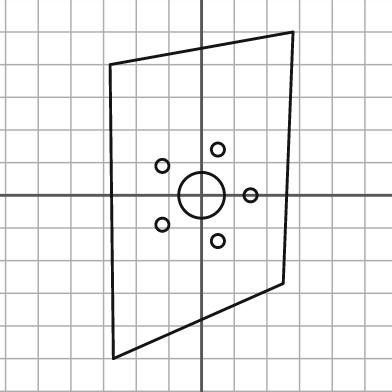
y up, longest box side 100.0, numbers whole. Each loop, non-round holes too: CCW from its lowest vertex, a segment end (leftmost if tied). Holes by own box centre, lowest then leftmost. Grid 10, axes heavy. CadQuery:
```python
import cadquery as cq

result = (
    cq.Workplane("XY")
    .moveTo(-27.0, -50.0)
    .lineTo(25.0, -27.0)
    .lineTo(28.0, 50.0)
    .lineTo(-28.0, 40.0)
    .close()
    .moveTo(5.0, -14.0)
    .circle(2.0)
    .moveTo(-12.0, -9.0)
    .circle(2.0)
    .moveTo(0.0, 0.0)
    .circle(7.0)
    .moveTo(15.0, 0.0)
    .circle(2.0)
    .moveTo(-12.0, 9.0)
    .circle(2.0)
    .moveTo(5.0, 14.0)
    .circle(2.0)
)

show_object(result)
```